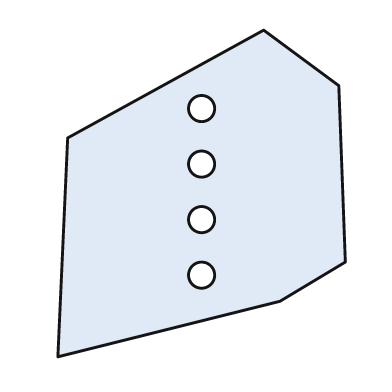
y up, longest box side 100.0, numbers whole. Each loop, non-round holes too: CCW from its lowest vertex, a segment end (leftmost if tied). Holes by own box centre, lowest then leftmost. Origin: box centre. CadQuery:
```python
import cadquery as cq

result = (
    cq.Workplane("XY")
    .moveTo(-44.0, -50.0)
    .lineTo(24.0, -33.0)
    .lineTo(44.0, -21.0)
    .lineTo(42.0, 33.0)
    .lineTo(19.0, 50.0)
    .lineTo(-41.0, 17.0)
    .close()
    .moveTo(0.0, -25.0)
    .circle(4.0)
    .moveTo(0.0, -8.0)
    .circle(4.0)
    .moveTo(0.0, 9.0)
    .circle(4.0)
    .moveTo(0.0, 26.0)
    .circle(4.0)
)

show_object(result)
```